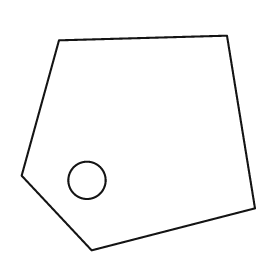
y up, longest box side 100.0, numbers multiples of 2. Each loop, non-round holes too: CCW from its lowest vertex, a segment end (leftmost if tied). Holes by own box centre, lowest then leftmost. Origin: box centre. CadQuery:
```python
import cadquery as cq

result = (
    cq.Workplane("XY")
    .moveTo(-20.0, -46.0)
    .lineTo(50.0, -28.0)
    .lineTo(38.0, 46.0)
    .lineTo(-34.0, 44.0)
    .lineTo(-50.0, -14.0)
    .close()
    .moveTo(-22.0, -16.0)
    .circle(8.0)
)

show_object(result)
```